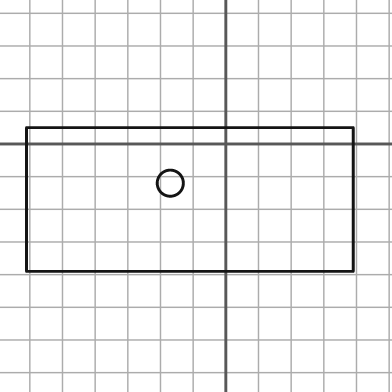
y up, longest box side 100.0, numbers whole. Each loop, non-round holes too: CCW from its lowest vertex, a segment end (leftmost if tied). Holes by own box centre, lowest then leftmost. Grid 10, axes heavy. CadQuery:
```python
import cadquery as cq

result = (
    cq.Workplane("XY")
    .moveTo(-61.0, -39.0)
    .lineTo(39.0, -39.0)
    .lineTo(39.0, 5.0)
    .lineTo(-61.0, 5.0)
    .close()
    .moveTo(-17.0, -12.0)
    .circle(4.0)
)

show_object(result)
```